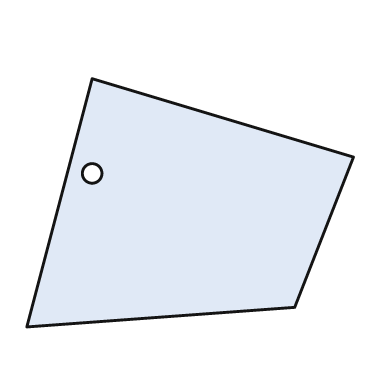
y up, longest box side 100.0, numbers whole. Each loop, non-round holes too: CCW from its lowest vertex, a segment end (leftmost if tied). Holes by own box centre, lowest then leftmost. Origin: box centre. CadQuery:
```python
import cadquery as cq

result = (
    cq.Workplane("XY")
    .moveTo(-50.0, -38.0)
    .lineTo(32.0, -32.0)
    .lineTo(50.0, 14.0)
    .lineTo(-30.0, 38.0)
    .close()
    .moveTo(-30.0, 9.0)
    .circle(3.0)
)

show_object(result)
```